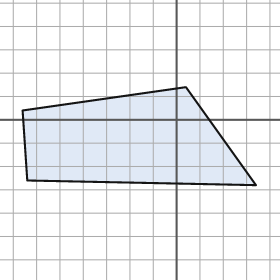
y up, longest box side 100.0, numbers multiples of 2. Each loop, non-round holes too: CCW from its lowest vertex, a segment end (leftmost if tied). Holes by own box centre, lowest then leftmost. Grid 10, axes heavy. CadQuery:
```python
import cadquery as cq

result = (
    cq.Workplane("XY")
    .moveTo(34.0, -28.0)
    .lineTo(4.0, 14.0)
    .lineTo(-66.0, 4.0)
    .lineTo(-64.0, -26.0)
    .close()
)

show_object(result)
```